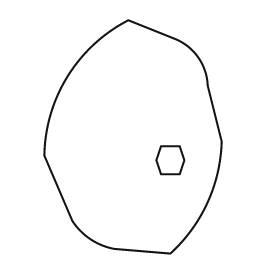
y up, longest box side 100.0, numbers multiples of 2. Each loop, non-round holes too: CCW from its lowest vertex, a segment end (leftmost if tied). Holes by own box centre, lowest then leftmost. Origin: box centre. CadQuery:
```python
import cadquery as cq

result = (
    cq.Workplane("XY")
    .moveTo(16.0, -50.0)
    .threePointArc((32.0, -28.0), (38.0, -2.0))
    .lineTo(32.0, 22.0)
    .threePointArc((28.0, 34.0), (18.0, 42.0))
    .lineTo(-2.0, 50.0)
    .threePointArc((-28.0, 26.0), (-38.0, -8.0))
    .lineTo(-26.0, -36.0)
    .threePointArc((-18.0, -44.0), (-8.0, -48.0))
    .close()
    .moveTo(12.0, -16.0)
    .lineTo(20.0, -16.0)
    .lineTo(22.0, -10.0)
    .lineTo(20.0, -4.0)
    .lineTo(12.0, -4.0)
    .lineTo(10.0, -10.0)
    .close()
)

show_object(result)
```